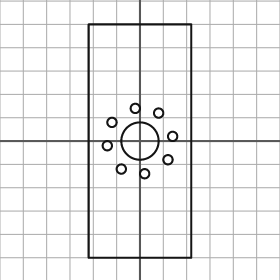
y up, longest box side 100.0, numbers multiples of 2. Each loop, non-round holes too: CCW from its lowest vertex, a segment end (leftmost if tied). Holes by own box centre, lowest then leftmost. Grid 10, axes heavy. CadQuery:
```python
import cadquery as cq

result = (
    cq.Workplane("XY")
    .moveTo(-22.0, -50.0)
    .lineTo(22.0, -50.0)
    .lineTo(22.0, 50.0)
    .lineTo(-22.0, 50.0)
    .close()
    .moveTo(2.0, -14.0)
    .circle(2.0)
    .moveTo(-8.0, -12.0)
    .circle(2.0)
    .moveTo(12.0, -8.0)
    .circle(2.0)
    .moveTo(-14.0, -2.0)
    .circle(2.0)
    .moveTo(0.0, 0.0)
    .circle(8.0)
    .moveTo(14.0, 2.0)
    .circle(2.0)
    .moveTo(-12.0, 8.0)
    .circle(2.0)
    .moveTo(8.0, 12.0)
    .circle(2.0)
    .moveTo(-2.0, 14.0)
    .circle(2.0)
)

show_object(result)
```